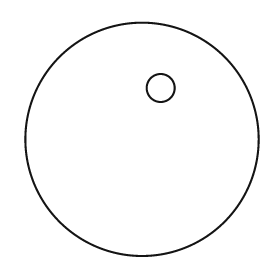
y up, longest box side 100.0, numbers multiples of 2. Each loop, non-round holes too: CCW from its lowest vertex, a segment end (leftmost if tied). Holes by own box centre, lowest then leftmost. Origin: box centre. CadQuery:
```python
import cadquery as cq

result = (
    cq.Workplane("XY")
    .moveTo(0.0, 0.0)
    .circle(50.0)
    .moveTo(8.0, 22.0)
    .circle(6.0)
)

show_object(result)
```